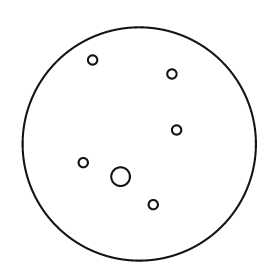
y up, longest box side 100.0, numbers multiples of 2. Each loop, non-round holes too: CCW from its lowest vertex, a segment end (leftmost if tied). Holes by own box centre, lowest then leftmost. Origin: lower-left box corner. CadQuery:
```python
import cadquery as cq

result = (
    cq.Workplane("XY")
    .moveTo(50.0, 50.0)
    .circle(50.0)
    .moveTo(56.0, 24.0)
    .circle(2.0)
    .moveTo(42.0, 36.0)
    .circle(4.0)
    .moveTo(26.0, 42.0)
    .circle(2.0)
    .moveTo(66.0, 56.0)
    .circle(2.0)
    .moveTo(64.0, 80.0)
    .circle(2.0)
    .moveTo(30.0, 86.0)
    .circle(2.0)
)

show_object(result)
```